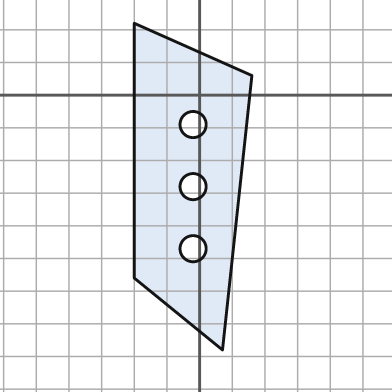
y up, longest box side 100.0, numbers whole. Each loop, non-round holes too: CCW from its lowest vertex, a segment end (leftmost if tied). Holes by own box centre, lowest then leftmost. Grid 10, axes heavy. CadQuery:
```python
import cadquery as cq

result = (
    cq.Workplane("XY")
    .moveTo(7.0, -78.0)
    .lineTo(16.0, 6.0)
    .lineTo(-20.0, 22.0)
    .lineTo(-20.0, -56.0)
    .close()
    .moveTo(-2.0, -47.0)
    .circle(4.0)
    .moveTo(-2.0, -28.0)
    .circle(4.0)
    .moveTo(-2.0, -9.0)
    .circle(4.0)
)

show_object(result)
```